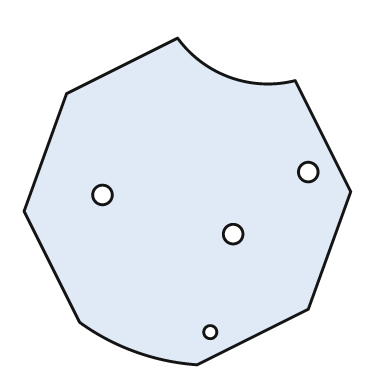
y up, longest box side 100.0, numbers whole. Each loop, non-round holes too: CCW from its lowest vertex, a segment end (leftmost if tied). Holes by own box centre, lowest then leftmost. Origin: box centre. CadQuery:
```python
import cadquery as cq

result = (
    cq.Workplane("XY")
    .moveTo(3.0, -50.0)
    .lineTo(37.0, -33.0)
    .lineTo(50.0, 3.0)
    .lineTo(33.0, 37.0)
    .threePointArc((13.0, 38.0), (-3.0, 50.0))
    .lineTo(-37.0, 33.0)
    .lineTo(-50.0, -3.0)
    .lineTo(-33.0, -37.0)
    .threePointArc((-16.0, -46.0), (3.0, -50.0))
    .close()
    .moveTo(7.0, -40.0)
    .circle(2.0)
    .moveTo(14.0, -10.0)
    .circle(3.0)
    .moveTo(-26.0, 2.0)
    .circle(3.0)
    .moveTo(37.0, 9.0)
    .circle(3.0)
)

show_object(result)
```